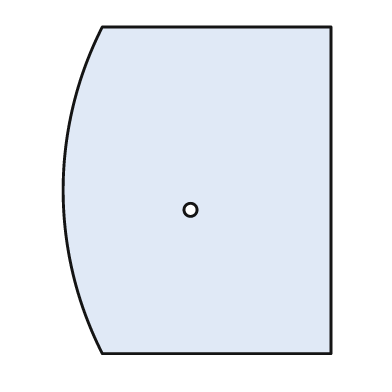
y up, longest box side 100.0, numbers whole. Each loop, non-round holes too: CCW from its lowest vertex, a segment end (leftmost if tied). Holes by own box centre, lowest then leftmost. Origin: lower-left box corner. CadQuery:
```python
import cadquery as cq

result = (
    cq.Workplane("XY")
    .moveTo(12.0, 0.0)
    .lineTo(82.0, 0.0)
    .lineTo(82.0, 100.0)
    .lineTo(12.0, 100.0)
    .threePointArc((0.0, 50.0), (12.0, 0.0))
    .close()
    .moveTo(39.0, 44.0)
    .circle(2.0)
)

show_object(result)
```